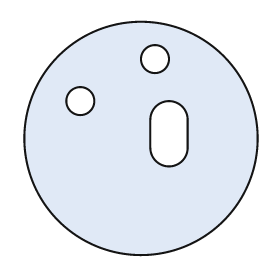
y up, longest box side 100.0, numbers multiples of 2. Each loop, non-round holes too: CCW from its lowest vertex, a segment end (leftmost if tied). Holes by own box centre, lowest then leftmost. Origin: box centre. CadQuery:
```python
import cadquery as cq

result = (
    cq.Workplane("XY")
    .moveTo(0.0, 0.0)
    .circle(50.0)
    .moveTo(4.0, -4.0)
    .threePointArc((12.0, -12.0), (20.0, -4.0))
    .lineTo(20.0, 8.0)
    .threePointArc((12.0, 16.0), (4.0, 8.0))
    .close()
    .moveTo(-26.0, 16.0)
    .circle(6.0)
    .moveTo(6.0, 34.0)
    .circle(6.0)
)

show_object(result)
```